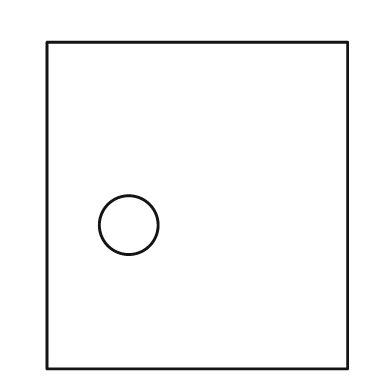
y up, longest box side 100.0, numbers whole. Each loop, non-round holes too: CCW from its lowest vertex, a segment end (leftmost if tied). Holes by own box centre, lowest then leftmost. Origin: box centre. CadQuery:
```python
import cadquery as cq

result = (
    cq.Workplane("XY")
    .moveTo(-46.0, -50.0)
    .lineTo(46.0, -50.0)
    .lineTo(46.0, 50.0)
    .lineTo(-46.0, 50.0)
    .close()
    .moveTo(-21.0, -6.0)
    .circle(9.0)
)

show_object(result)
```